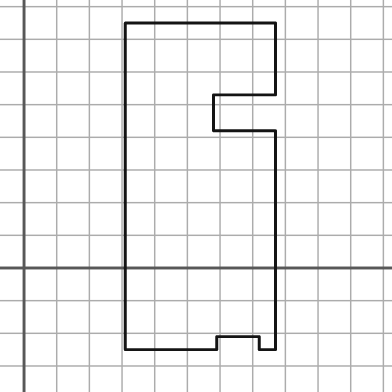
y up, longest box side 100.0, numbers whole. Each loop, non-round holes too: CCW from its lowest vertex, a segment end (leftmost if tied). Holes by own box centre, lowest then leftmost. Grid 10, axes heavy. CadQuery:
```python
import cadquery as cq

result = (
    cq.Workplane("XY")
    .moveTo(31.0, -25.0)
    .lineTo(59.0, -25.0)
    .lineTo(59.0, -21.0)
    .lineTo(72.0, -21.0)
    .lineTo(72.0, -25.0)
    .lineTo(77.0, -25.0)
    .lineTo(77.0, 42.0)
    .lineTo(58.0, 42.0)
    .lineTo(58.0, 53.0)
    .lineTo(77.0, 53.0)
    .lineTo(77.0, 75.0)
    .lineTo(31.0, 75.0)
    .close()
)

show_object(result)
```